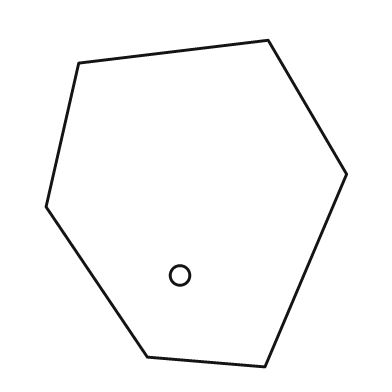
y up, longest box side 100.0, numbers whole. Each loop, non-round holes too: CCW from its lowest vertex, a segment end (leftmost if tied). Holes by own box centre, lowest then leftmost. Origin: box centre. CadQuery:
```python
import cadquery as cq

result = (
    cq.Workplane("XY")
    .moveTo(21.0, -50.0)
    .lineTo(46.0, 9.0)
    .lineTo(22.0, 50.0)
    .lineTo(-36.0, 43.0)
    .lineTo(-46.0, -1.0)
    .lineTo(-15.0, -47.0)
    .close()
    .moveTo(-5.0, -22.0)
    .circle(3.0)
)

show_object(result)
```